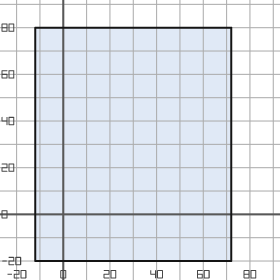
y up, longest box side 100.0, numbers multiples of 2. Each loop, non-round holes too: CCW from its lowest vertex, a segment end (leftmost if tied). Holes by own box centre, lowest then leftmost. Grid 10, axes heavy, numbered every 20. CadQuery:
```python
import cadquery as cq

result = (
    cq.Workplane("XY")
    .moveTo(-12.0, -20.0)
    .lineTo(72.0, -20.0)
    .lineTo(72.0, 80.0)
    .lineTo(-12.0, 80.0)
    .close()
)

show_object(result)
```